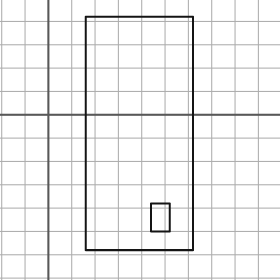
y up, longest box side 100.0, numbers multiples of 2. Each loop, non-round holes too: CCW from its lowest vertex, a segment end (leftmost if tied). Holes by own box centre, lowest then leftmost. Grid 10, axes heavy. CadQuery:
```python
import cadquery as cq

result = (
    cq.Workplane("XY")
    .moveTo(16.0, -58.0)
    .lineTo(62.0, -58.0)
    .lineTo(62.0, 42.0)
    .lineTo(16.0, 42.0)
    .close()
    .moveTo(44.0, -50.0)
    .lineTo(52.0, -50.0)
    .lineTo(52.0, -38.0)
    .lineTo(44.0, -38.0)
    .close()
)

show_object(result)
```